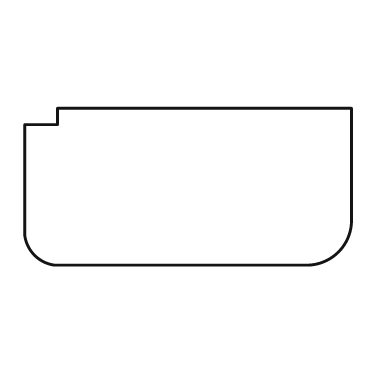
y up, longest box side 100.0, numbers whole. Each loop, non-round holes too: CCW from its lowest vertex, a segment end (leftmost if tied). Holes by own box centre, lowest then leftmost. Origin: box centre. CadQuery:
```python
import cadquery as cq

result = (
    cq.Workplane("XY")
    .moveTo(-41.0, -24.0)
    .lineTo(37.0, -24.0)
    .threePointArc((46.0, -20.0), (50.0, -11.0))
    .lineTo(50.0, 24.0)
    .lineTo(-40.0, 24.0)
    .lineTo(-40.0, 19.0)
    .lineTo(-50.0, 19.0)
    .lineTo(-50.0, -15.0)
    .threePointArc((-47.0, -21.0), (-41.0, -24.0))
    .close()
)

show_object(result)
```